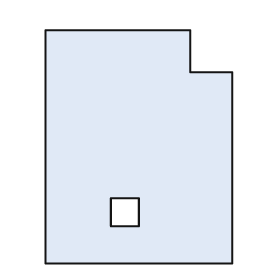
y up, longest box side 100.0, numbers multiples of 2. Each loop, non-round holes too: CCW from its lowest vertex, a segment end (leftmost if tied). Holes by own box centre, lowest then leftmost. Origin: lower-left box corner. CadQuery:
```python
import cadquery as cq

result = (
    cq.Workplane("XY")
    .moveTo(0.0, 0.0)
    .lineTo(80.0, 0.0)
    .lineTo(80.0, 82.0)
    .lineTo(62.0, 82.0)
    .lineTo(62.0, 100.0)
    .lineTo(0.0, 100.0)
    .close()
    .moveTo(28.0, 16.0)
    .lineTo(40.0, 16.0)
    .lineTo(40.0, 28.0)
    .lineTo(28.0, 28.0)
    .close()
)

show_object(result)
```